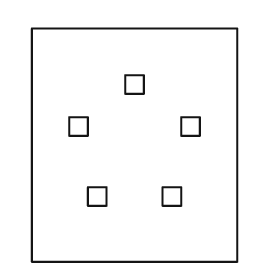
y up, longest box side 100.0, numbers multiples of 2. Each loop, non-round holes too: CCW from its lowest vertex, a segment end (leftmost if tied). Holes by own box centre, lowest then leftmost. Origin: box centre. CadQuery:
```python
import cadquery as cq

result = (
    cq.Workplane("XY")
    .moveTo(-44.0, -50.0)
    .lineTo(44.0, -50.0)
    .lineTo(44.0, 50.0)
    .lineTo(-44.0, 50.0)
    .close()
    .moveTo(-20.0, -26.0)
    .lineTo(-12.0, -26.0)
    .lineTo(-12.0, -18.0)
    .lineTo(-20.0, -18.0)
    .close()
    .moveTo(12.0, -26.0)
    .lineTo(20.0, -26.0)
    .lineTo(20.0, -18.0)
    .lineTo(12.0, -18.0)
    .close()
    .moveTo(-28.0, 4.0)
    .lineTo(-20.0, 4.0)
    .lineTo(-20.0, 12.0)
    .lineTo(-28.0, 12.0)
    .close()
    .moveTo(20.0, 4.0)
    .lineTo(28.0, 4.0)
    .lineTo(28.0, 12.0)
    .lineTo(20.0, 12.0)
    .close()
    .moveTo(-4.0, 22.0)
    .lineTo(4.0, 22.0)
    .lineTo(4.0, 30.0)
    .lineTo(-4.0, 30.0)
    .close()
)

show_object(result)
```